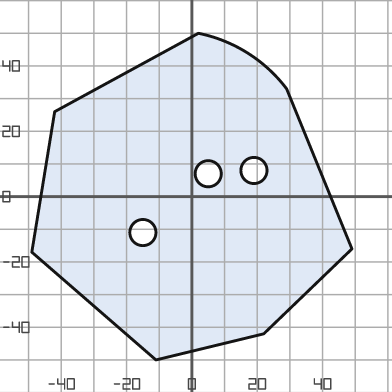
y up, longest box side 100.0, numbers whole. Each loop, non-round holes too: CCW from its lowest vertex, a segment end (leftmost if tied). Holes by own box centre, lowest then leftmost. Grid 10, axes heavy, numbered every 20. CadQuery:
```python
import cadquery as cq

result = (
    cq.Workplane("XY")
    .moveTo(-11.0, -50.0)
    .lineTo(22.0, -42.0)
    .lineTo(49.0, -16.0)
    .lineTo(29.0, 33.0)
    .threePointArc((17.0, 44.0), (2.0, 50.0))
    .lineTo(-42.0, 26.0)
    .lineTo(-49.0, -17.0)
    .close()
    .moveTo(-15.0, -11.0)
    .circle(4.0)
    .moveTo(5.0, 7.0)
    .circle(4.0)
    .moveTo(19.0, 8.0)
    .circle(4.0)
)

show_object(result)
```